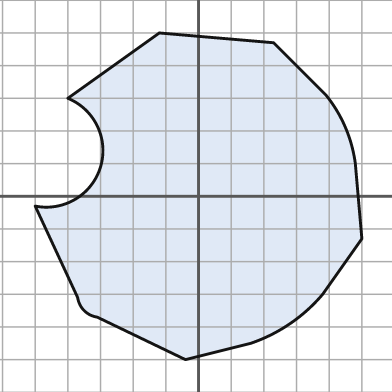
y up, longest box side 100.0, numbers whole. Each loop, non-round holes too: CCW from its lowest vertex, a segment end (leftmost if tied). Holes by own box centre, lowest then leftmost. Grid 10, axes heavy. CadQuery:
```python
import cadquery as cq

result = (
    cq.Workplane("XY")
    .moveTo(-4.0, -50.0)
    .lineTo(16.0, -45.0)
    .threePointArc((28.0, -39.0), (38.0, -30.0))
    .lineTo(50.0, -13.0)
    .lineTo(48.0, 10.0)
    .threePointArc((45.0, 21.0), (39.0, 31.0))
    .lineTo(23.0, 47.0)
    .lineTo(-12.0, 50.0)
    .lineTo(-40.0, 30.0)
    .threePointArc((-30.0, 9.0), (-50.0, -3.0))
    .lineTo(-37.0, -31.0)
    .threePointArc((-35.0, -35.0), (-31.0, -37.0))
    .close()
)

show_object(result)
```